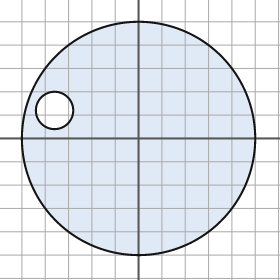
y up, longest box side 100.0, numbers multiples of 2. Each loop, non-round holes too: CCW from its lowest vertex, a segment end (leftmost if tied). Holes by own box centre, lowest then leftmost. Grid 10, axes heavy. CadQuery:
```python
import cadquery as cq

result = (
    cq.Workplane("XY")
    .moveTo(0.0, 0.0)
    .circle(50.0)
    .moveTo(-36.0, 12.0)
    .circle(8.0)
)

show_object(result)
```